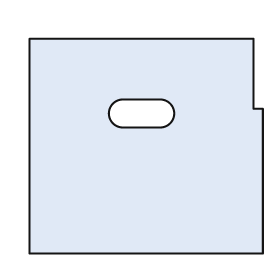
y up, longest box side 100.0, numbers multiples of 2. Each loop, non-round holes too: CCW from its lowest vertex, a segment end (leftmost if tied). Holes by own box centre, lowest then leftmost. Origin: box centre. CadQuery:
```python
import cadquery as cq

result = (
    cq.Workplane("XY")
    .moveTo(-50.0, -46.0)
    .lineTo(50.0, -46.0)
    .lineTo(50.0, 16.0)
    .lineTo(46.0, 16.0)
    .lineTo(46.0, 46.0)
    .lineTo(-50.0, 46.0)
    .close()
    .moveTo(-10.0, 8.0)
    .lineTo(6.0, 8.0)
    .threePointArc((12.0, 14.0), (6.0, 20.0))
    .lineTo(-10.0, 20.0)
    .threePointArc((-16.0, 14.0), (-10.0, 8.0))
    .close()
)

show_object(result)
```